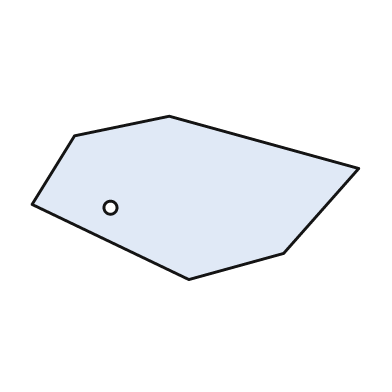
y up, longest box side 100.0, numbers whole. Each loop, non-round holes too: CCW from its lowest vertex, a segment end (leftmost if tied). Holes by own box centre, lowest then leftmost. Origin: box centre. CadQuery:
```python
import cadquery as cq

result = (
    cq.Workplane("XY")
    .moveTo(-2.0, -25.0)
    .lineTo(27.0, -17.0)
    .lineTo(50.0, 9.0)
    .lineTo(-8.0, 25.0)
    .lineTo(-37.0, 19.0)
    .lineTo(-50.0, -2.0)
    .close()
    .moveTo(-26.0, -3.0)
    .circle(2.0)
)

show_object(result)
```